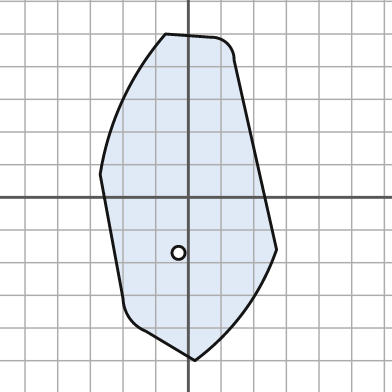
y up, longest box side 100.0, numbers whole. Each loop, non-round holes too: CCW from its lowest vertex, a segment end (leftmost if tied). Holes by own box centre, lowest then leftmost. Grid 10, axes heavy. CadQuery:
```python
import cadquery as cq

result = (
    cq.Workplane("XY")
    .moveTo(2.0, -50.0)
    .threePointArc((17.0, -35.0), (27.0, -16.0))
    .lineTo(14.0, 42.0)
    .threePointArc((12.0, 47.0), (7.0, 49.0))
    .lineTo(-7.0, 50.0)
    .threePointArc((-20.0, 30.0), (-27.0, 7.0))
    .lineTo(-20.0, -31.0)
    .threePointArc((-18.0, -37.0), (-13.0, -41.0))
    .close()
    .moveTo(-3.0, -17.0)
    .circle(2.0)
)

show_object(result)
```